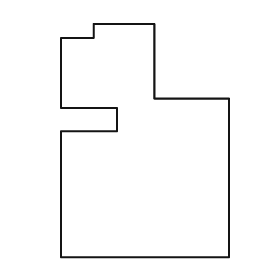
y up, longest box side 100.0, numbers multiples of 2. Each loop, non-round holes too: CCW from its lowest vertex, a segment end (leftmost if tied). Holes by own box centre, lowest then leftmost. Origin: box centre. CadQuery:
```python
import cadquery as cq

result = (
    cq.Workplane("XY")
    .moveTo(-36.0, -50.0)
    .lineTo(36.0, -50.0)
    .lineTo(36.0, 18.0)
    .lineTo(4.0, 18.0)
    .lineTo(4.0, 50.0)
    .lineTo(-22.0, 50.0)
    .lineTo(-22.0, 44.0)
    .lineTo(-36.0, 44.0)
    .lineTo(-36.0, 14.0)
    .lineTo(-12.0, 14.0)
    .lineTo(-12.0, 4.0)
    .lineTo(-36.0, 4.0)
    .close()
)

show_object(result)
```